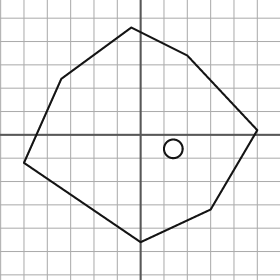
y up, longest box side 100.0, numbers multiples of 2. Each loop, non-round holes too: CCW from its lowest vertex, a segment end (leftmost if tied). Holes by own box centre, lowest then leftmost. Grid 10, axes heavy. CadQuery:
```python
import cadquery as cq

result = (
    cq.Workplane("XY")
    .moveTo(0.0, -46.0)
    .lineTo(30.0, -32.0)
    .lineTo(50.0, 2.0)
    .lineTo(20.0, 34.0)
    .lineTo(-4.0, 46.0)
    .lineTo(-34.0, 24.0)
    .lineTo(-50.0, -12.0)
    .close()
    .moveTo(14.0, -6.0)
    .circle(4.0)
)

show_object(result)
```